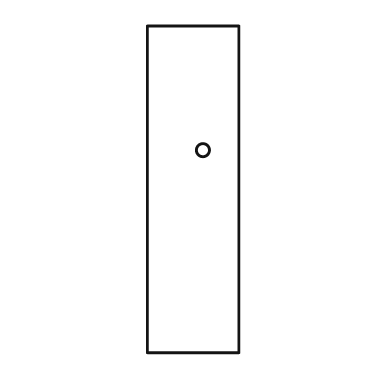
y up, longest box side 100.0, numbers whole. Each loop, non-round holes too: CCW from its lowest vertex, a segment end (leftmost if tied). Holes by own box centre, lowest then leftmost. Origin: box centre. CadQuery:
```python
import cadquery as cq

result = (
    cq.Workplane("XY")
    .moveTo(-14.0, -50.0)
    .lineTo(14.0, -50.0)
    .lineTo(14.0, 50.0)
    .lineTo(-14.0, 50.0)
    .close()
    .moveTo(3.0, 12.0)
    .circle(2.0)
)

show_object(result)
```